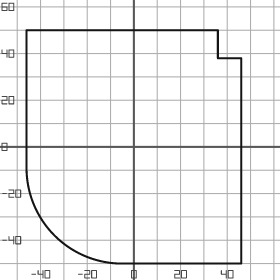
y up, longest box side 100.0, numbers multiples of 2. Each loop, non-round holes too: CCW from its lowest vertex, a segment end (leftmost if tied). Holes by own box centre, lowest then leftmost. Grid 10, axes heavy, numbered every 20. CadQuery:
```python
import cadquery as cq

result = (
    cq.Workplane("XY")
    .moveTo(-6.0, -50.0)
    .lineTo(46.0, -50.0)
    .lineTo(46.0, 38.0)
    .lineTo(36.0, 38.0)
    .lineTo(36.0, 50.0)
    .lineTo(-46.0, 50.0)
    .lineTo(-46.0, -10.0)
    .threePointArc((-34.0, -38.0), (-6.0, -50.0))
    .close()
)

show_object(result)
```